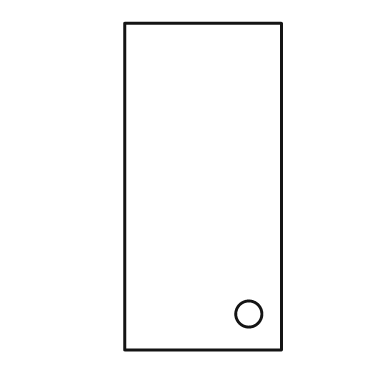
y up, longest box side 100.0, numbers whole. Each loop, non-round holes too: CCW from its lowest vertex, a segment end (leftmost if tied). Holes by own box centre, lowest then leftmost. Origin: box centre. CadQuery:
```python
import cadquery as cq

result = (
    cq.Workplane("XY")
    .moveTo(-24.0, -50.0)
    .lineTo(24.0, -50.0)
    .lineTo(24.0, 50.0)
    .lineTo(-24.0, 50.0)
    .close()
    .moveTo(14.0, -39.0)
    .circle(4.0)
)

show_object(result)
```